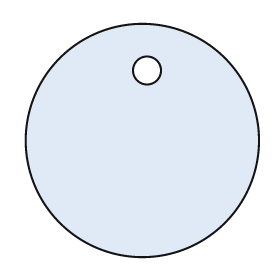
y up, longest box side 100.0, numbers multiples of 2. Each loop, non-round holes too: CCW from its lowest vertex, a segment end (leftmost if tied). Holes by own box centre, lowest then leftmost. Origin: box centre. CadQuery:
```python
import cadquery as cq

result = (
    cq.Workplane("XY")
    .moveTo(0.0, 0.0)
    .circle(50.0)
    .moveTo(2.0, 30.0)
    .circle(6.0)
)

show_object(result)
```